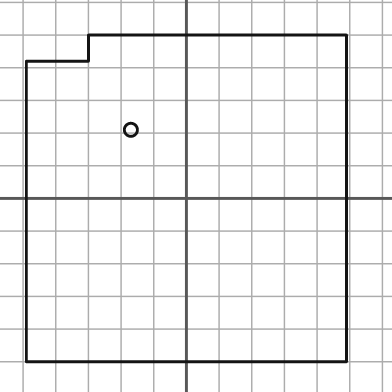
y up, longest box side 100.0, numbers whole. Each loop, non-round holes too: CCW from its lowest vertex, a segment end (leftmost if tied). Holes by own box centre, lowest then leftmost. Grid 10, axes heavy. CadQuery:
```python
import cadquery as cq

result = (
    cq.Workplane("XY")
    .moveTo(-49.0, -50.0)
    .lineTo(49.0, -50.0)
    .lineTo(49.0, 50.0)
    .lineTo(-30.0, 50.0)
    .lineTo(-30.0, 42.0)
    .lineTo(-49.0, 42.0)
    .close()
    .moveTo(-17.0, 21.0)
    .circle(2.0)
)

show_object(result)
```